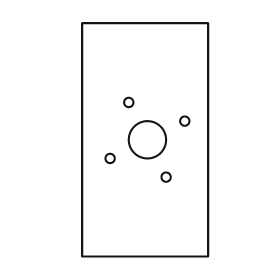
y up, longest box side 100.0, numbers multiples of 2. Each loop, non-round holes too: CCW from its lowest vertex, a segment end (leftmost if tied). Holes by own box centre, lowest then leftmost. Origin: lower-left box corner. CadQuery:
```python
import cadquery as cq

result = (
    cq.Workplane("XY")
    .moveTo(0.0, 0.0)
    .lineTo(54.0, 0.0)
    .lineTo(54.0, 100.0)
    .lineTo(0.0, 100.0)
    .close()
    .moveTo(36.0, 34.0)
    .circle(2.0)
    .moveTo(12.0, 42.0)
    .circle(2.0)
    .moveTo(28.0, 50.0)
    .circle(8.0)
    .moveTo(44.0, 58.0)
    .circle(2.0)
    .moveTo(20.0, 66.0)
    .circle(2.0)
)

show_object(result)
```